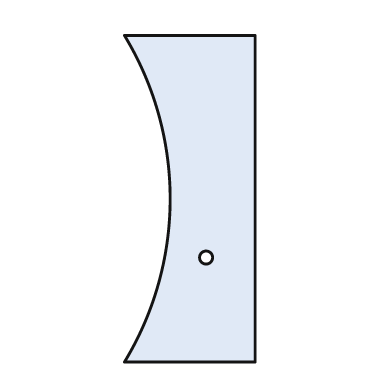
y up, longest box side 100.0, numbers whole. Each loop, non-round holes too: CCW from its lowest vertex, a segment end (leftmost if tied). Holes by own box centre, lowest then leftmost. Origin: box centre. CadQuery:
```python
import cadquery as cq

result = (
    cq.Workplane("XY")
    .moveTo(-20.0, -50.0)
    .lineTo(20.0, -50.0)
    .lineTo(20.0, 50.0)
    .lineTo(-20.0, 50.0)
    .threePointArc((-6.0, 0.0), (-20.0, -50.0))
    .close()
    .moveTo(5.0, -18.0)
    .circle(2.0)
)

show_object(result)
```